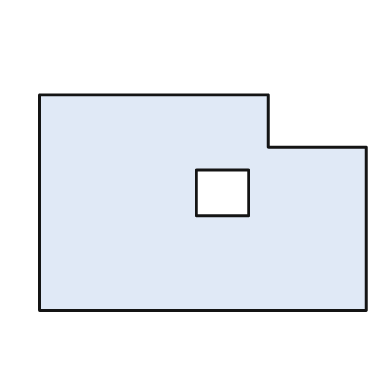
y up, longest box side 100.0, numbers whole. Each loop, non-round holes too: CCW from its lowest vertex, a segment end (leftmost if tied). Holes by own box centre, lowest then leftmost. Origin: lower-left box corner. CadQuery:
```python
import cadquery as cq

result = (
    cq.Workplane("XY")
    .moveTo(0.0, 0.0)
    .lineTo(100.0, 0.0)
    .lineTo(100.0, 50.0)
    .lineTo(70.0, 50.0)
    .lineTo(70.0, 66.0)
    .lineTo(0.0, 66.0)
    .close()
    .moveTo(48.0, 29.0)
    .lineTo(64.0, 29.0)
    .lineTo(64.0, 43.0)
    .lineTo(48.0, 43.0)
    .close()
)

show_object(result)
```